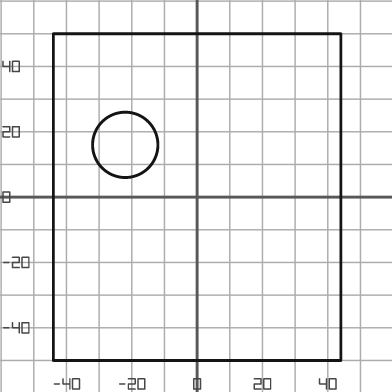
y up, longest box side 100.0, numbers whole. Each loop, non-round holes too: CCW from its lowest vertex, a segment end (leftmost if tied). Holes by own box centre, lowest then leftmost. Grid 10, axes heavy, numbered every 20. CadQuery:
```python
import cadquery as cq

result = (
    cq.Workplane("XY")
    .moveTo(-44.0, -50.0)
    .lineTo(44.0, -50.0)
    .lineTo(44.0, 50.0)
    .lineTo(-44.0, 50.0)
    .close()
    .moveTo(-22.0, 16.0)
    .circle(10.0)
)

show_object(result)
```